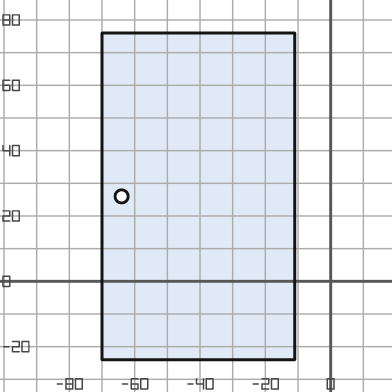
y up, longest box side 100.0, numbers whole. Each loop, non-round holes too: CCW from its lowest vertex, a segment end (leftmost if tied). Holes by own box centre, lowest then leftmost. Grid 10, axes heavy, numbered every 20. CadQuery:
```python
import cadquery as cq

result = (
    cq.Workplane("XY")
    .moveTo(-70.0, -24.0)
    .lineTo(-11.0, -24.0)
    .lineTo(-11.0, 76.0)
    .lineTo(-70.0, 76.0)
    .close()
    .moveTo(-64.0, 26.0)
    .circle(2.0)
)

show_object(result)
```